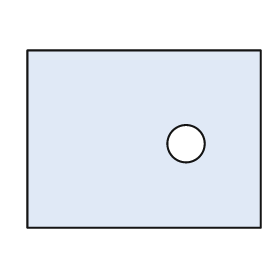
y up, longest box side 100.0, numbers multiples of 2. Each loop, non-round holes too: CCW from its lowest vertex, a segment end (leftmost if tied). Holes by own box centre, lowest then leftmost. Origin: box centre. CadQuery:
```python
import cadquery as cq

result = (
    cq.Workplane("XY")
    .moveTo(-50.0, -38.0)
    .lineTo(50.0, -38.0)
    .lineTo(50.0, 38.0)
    .lineTo(-50.0, 38.0)
    .close()
    .moveTo(18.0, -2.0)
    .circle(8.0)
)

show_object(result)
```